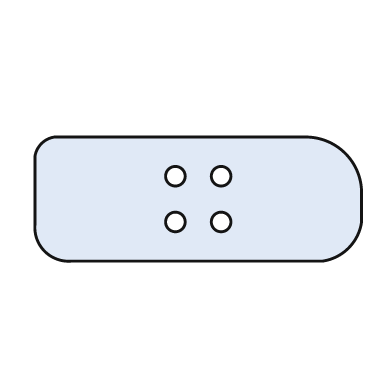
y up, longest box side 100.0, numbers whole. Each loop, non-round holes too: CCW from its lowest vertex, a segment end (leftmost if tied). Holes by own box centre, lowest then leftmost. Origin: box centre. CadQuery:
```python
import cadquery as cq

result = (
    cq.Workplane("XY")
    .moveTo(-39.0, -19.0)
    .lineTo(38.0, -19.0)
    .threePointArc((46.0, -15.0), (50.0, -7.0))
    .lineTo(50.0, 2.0)
    .threePointArc((45.0, 14.0), (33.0, 19.0))
    .lineTo(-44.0, 19.0)
    .threePointArc((-48.0, 17.0), (-50.0, 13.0))
    .lineTo(-50.0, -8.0)
    .threePointArc((-47.0, -16.0), (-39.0, -19.0))
    .close()
    .moveTo(-7.0, -7.0)
    .circle(3.0)
    .moveTo(7.0, -7.0)
    .circle(3.0)
    .moveTo(-7.0, 7.0)
    .circle(3.0)
    .moveTo(7.0, 7.0)
    .circle(3.0)
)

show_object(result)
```